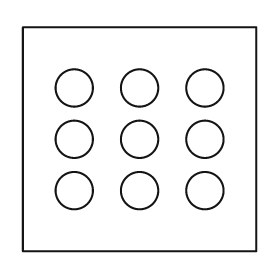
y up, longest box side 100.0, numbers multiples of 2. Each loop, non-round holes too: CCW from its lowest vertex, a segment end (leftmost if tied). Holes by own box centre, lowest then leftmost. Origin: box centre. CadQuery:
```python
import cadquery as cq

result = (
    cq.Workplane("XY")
    .moveTo(-50.0, -48.0)
    .lineTo(50.0, -48.0)
    .lineTo(50.0, 48.0)
    .lineTo(-50.0, 48.0)
    .close()
    .moveTo(-28.0, -22.0)
    .circle(8.0)
    .moveTo(0.0, -22.0)
    .circle(8.0)
    .moveTo(28.0, -22.0)
    .circle(8.0)
    .moveTo(-28.0, 0.0)
    .circle(8.0)
    .moveTo(0.0, 0.0)
    .circle(8.0)
    .moveTo(28.0, 0.0)
    .circle(8.0)
    .moveTo(-28.0, 22.0)
    .circle(8.0)
    .moveTo(0.0, 22.0)
    .circle(8.0)
    .moveTo(28.0, 22.0)
    .circle(8.0)
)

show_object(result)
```